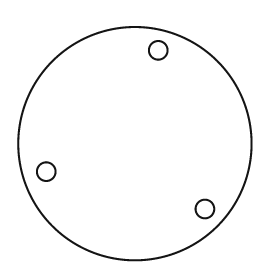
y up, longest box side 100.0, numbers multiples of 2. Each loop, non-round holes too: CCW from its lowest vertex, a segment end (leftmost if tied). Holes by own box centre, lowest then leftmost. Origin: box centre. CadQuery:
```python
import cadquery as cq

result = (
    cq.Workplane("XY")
    .moveTo(0.0, 0.0)
    .circle(50.0)
    .moveTo(30.0, -28.0)
    .circle(4.0)
    .moveTo(-38.0, -12.0)
    .circle(4.0)
    .moveTo(10.0, 40.0)
    .circle(4.0)
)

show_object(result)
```